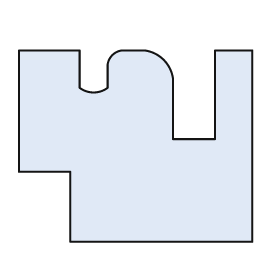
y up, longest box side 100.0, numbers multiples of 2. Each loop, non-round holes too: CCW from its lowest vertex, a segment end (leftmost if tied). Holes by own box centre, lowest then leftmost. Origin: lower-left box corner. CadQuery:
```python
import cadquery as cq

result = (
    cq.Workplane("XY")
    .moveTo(22.0, 0.0)
    .lineTo(100.0, 0.0)
    .lineTo(100.0, 82.0)
    .lineTo(84.0, 82.0)
    .lineTo(84.0, 44.0)
    .lineTo(66.0, 44.0)
    .lineTo(66.0, 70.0)
    .threePointArc((62.0, 78.0), (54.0, 82.0))
    .lineTo(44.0, 82.0)
    .threePointArc((40.0, 80.0), (38.0, 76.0))
    .lineTo(38.0, 66.0)
    .threePointArc((32.0, 64.0), (26.0, 66.0))
    .lineTo(26.0, 82.0)
    .lineTo(0.0, 82.0)
    .lineTo(0.0, 30.0)
    .lineTo(22.0, 30.0)
    .close()
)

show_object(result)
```